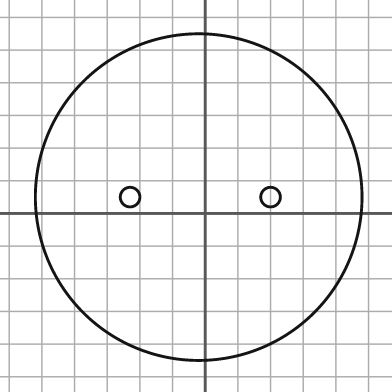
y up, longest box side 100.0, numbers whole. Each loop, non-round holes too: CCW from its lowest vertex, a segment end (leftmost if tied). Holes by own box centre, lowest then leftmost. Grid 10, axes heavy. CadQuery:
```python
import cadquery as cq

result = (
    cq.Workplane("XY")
    .moveTo(-2.0, 5.0)
    .circle(50.0)
    .moveTo(-23.0, 5.0)
    .circle(3.0)
    .moveTo(20.0, 5.0)
    .circle(3.0)
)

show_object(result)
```